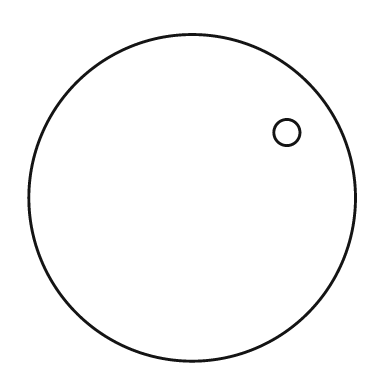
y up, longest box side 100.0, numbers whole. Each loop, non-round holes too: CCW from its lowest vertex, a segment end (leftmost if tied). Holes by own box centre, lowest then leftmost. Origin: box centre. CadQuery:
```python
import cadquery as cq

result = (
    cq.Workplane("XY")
    .moveTo(0.0, 0.0)
    .circle(50.0)
    .moveTo(29.0, 20.0)
    .circle(4.0)
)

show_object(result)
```